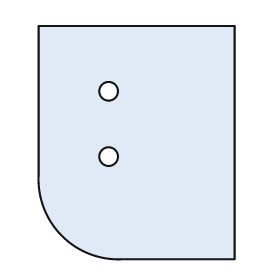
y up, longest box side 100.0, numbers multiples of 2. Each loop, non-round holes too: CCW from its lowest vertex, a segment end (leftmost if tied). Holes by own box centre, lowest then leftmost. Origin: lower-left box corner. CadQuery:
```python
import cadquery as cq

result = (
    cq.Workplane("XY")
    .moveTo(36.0, 0.0)
    .lineTo(84.0, 0.0)
    .lineTo(84.0, 100.0)
    .lineTo(0.0, 100.0)
    .lineTo(0.0, 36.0)
    .threePointArc((10.0, 10.0), (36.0, 0.0))
    .close()
    .moveTo(30.0, 44.0)
    .circle(4.0)
    .moveTo(30.0, 72.0)
    .circle(4.0)
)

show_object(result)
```